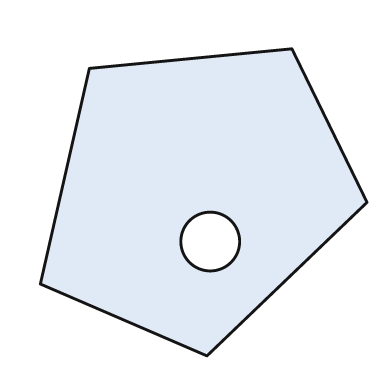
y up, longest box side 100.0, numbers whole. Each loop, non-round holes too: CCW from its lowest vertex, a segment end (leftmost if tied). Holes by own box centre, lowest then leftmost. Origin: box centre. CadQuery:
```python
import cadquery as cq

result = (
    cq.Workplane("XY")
    .moveTo(1.0, -47.0)
    .lineTo(50.0, 0.0)
    .lineTo(27.0, 47.0)
    .lineTo(-35.0, 41.0)
    .lineTo(-50.0, -25.0)
    .close()
    .moveTo(2.0, -12.0)
    .circle(9.0)
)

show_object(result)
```